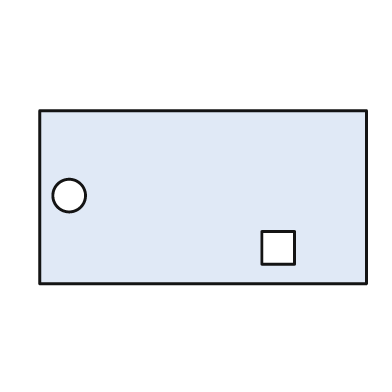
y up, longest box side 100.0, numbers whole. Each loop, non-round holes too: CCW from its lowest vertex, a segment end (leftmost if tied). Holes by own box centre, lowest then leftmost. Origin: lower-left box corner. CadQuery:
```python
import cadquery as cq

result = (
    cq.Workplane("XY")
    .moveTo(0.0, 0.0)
    .lineTo(100.0, 0.0)
    .lineTo(100.0, 53.0)
    .lineTo(0.0, 53.0)
    .close()
    .moveTo(68.0, 6.0)
    .lineTo(78.0, 6.0)
    .lineTo(78.0, 16.0)
    .lineTo(68.0, 16.0)
    .close()
    .moveTo(9.0, 27.0)
    .circle(5.0)
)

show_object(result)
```